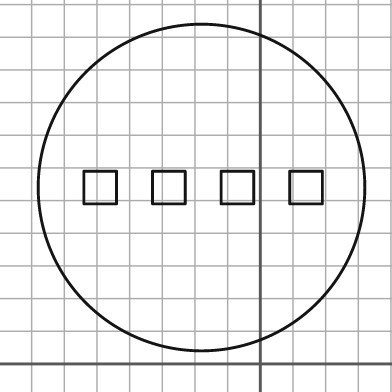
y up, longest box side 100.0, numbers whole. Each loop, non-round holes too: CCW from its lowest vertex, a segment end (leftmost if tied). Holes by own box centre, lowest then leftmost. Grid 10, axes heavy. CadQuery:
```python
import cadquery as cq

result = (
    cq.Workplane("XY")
    .moveTo(-18.0, 54.0)
    .circle(50.0)
    .moveTo(-54.0, 49.0)
    .lineTo(-44.0, 49.0)
    .lineTo(-44.0, 59.0)
    .lineTo(-54.0, 59.0)
    .close()
    .moveTo(-33.0, 49.0)
    .lineTo(-23.0, 49.0)
    .lineTo(-23.0, 59.0)
    .lineTo(-33.0, 59.0)
    .close()
    .moveTo(-12.0, 49.0)
    .lineTo(-2.0, 49.0)
    .lineTo(-2.0, 59.0)
    .lineTo(-12.0, 59.0)
    .close()
    .moveTo(9.0, 49.0)
    .lineTo(19.0, 49.0)
    .lineTo(19.0, 59.0)
    .lineTo(9.0, 59.0)
    .close()
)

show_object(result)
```